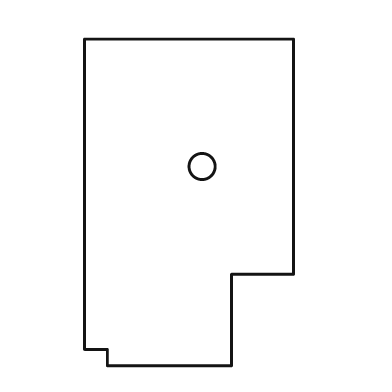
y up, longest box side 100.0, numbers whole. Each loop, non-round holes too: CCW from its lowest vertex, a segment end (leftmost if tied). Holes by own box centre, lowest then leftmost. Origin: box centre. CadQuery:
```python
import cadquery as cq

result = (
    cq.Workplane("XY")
    .moveTo(-25.0, -50.0)
    .lineTo(13.0, -50.0)
    .lineTo(13.0, -22.0)
    .lineTo(32.0, -22.0)
    .lineTo(32.0, 50.0)
    .lineTo(-32.0, 50.0)
    .lineTo(-32.0, -45.0)
    .lineTo(-25.0, -45.0)
    .close()
    .moveTo(4.0, 11.0)
    .circle(4.0)
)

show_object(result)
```